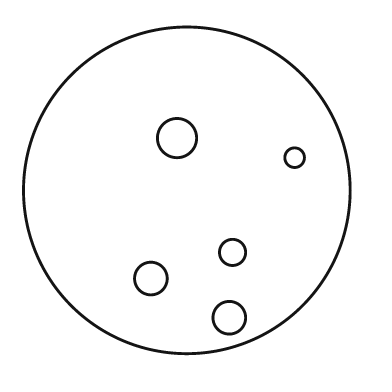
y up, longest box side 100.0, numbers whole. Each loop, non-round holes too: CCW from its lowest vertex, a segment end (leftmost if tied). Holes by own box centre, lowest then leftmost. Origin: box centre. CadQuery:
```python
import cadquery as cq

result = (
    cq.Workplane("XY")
    .moveTo(0.0, 0.0)
    .circle(50.0)
    .moveTo(13.0, -39.0)
    .circle(5.0)
    .moveTo(-11.0, -27.0)
    .circle(5.0)
    .moveTo(14.0, -19.0)
    .circle(4.0)
    .moveTo(33.0, 10.0)
    .circle(3.0)
    .moveTo(-3.0, 16.0)
    .circle(6.0)
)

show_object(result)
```